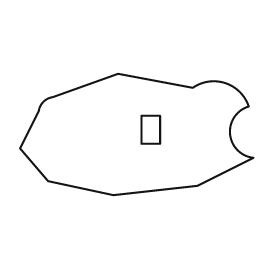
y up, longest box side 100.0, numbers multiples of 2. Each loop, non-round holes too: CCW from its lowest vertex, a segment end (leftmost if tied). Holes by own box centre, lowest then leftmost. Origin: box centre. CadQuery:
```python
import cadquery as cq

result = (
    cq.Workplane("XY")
    .moveTo(-10.0, -26.0)
    .lineTo(26.0, -22.0)
    .lineTo(50.0, -10.0)
    .threePointArc((40.0, 0.0), (48.0, 12.0))
    .threePointArc((38.0, 22.0), (24.0, 20.0))
    .lineTo(-8.0, 26.0)
    .lineTo(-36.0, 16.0)
    .threePointArc((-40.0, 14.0), (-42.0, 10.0))
    .lineTo(-50.0, -6.0)
    .lineTo(-38.0, -20.0)
    .close()
    .moveTo(2.0, -4.0)
    .lineTo(10.0, -4.0)
    .lineTo(10.0, 8.0)
    .lineTo(2.0, 8.0)
    .close()
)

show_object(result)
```